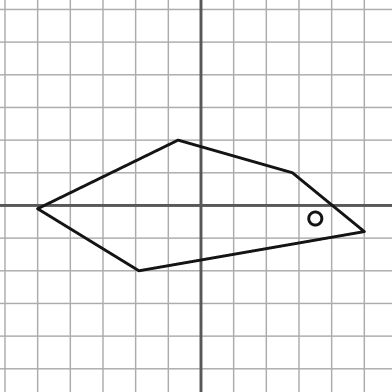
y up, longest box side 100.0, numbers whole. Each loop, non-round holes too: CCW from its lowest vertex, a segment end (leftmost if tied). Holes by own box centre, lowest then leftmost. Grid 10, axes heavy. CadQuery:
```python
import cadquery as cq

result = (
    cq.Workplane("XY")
    .moveTo(-19.0, -20.0)
    .lineTo(50.0, -8.0)
    .lineTo(28.0, 10.0)
    .lineTo(-7.0, 20.0)
    .lineTo(-50.0, -1.0)
    .close()
    .moveTo(35.0, -4.0)
    .circle(2.0)
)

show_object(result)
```